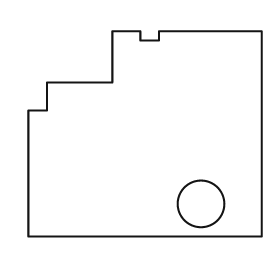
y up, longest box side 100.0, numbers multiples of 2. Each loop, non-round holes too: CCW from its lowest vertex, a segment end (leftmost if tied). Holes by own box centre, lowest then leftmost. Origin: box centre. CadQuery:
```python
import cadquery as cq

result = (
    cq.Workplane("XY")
    .moveTo(-50.0, -44.0)
    .lineTo(50.0, -44.0)
    .lineTo(50.0, 44.0)
    .lineTo(6.0, 44.0)
    .lineTo(6.0, 40.0)
    .lineTo(-2.0, 40.0)
    .lineTo(-2.0, 44.0)
    .lineTo(-14.0, 44.0)
    .lineTo(-14.0, 22.0)
    .lineTo(-42.0, 22.0)
    .lineTo(-42.0, 10.0)
    .lineTo(-50.0, 10.0)
    .close()
    .moveTo(24.0, -30.0)
    .circle(10.0)
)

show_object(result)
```